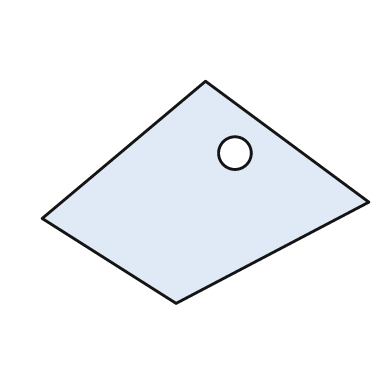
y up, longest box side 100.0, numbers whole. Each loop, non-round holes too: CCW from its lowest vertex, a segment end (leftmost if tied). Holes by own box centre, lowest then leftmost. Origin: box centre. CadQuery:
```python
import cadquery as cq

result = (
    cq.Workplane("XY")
    .moveTo(-9.0, -34.0)
    .lineTo(50.0, -3.0)
    .lineTo(0.0, 34.0)
    .lineTo(-50.0, -8.0)
    .close()
    .moveTo(9.0, 12.0)
    .circle(5.0)
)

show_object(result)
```